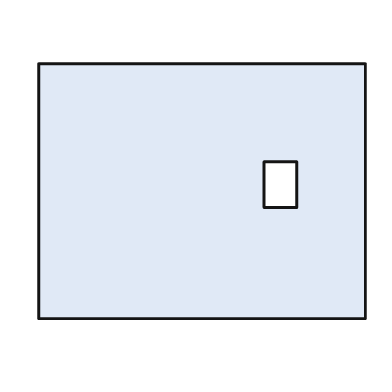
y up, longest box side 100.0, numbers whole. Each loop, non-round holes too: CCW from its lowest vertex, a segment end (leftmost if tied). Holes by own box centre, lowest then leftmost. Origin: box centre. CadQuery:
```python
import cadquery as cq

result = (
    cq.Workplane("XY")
    .moveTo(-50.0, -39.0)
    .lineTo(50.0, -39.0)
    .lineTo(50.0, 39.0)
    .lineTo(-50.0, 39.0)
    .close()
    .moveTo(19.0, -5.0)
    .lineTo(29.0, -5.0)
    .lineTo(29.0, 9.0)
    .lineTo(19.0, 9.0)
    .close()
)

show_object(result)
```